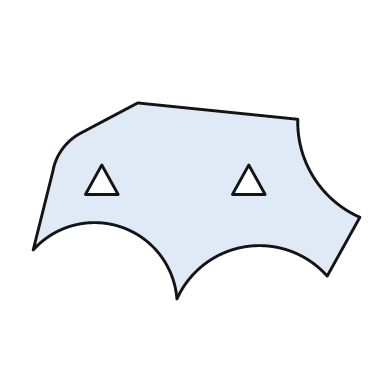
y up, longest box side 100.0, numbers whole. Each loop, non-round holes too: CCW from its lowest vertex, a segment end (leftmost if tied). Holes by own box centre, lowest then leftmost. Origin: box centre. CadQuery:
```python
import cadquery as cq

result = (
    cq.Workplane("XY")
    .moveTo(-6.0, -30.0)
    .threePointArc((15.0, -14.0), (40.0, -23.0))
    .lineTo(50.0, -5.0)
    .threePointArc((36.0, 7.0), (31.0, 25.0))
    .lineTo(-18.0, 30.0)
    .lineTo(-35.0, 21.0)
    .threePointArc((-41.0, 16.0), (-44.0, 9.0))
    .lineTo(-50.0, -15.0)
    .threePointArc((-23.0, -8.0), (-6.0, -30.0))
    .close()
    .moveTo(-34.0, 2.0)
    .lineTo(-24.0, 2.0)
    .lineTo(-29.0, 11.0)
    .close()
    .moveTo(11.0, 2.0)
    .lineTo(21.0, 2.0)
    .lineTo(16.0, 11.0)
    .close()
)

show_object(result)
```